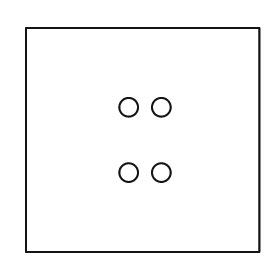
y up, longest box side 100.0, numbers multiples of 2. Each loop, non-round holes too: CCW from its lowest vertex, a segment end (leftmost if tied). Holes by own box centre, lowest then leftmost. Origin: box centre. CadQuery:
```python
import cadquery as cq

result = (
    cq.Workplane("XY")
    .moveTo(-50.0, -48.0)
    .lineTo(50.0, -48.0)
    .lineTo(50.0, 48.0)
    .lineTo(-50.0, 48.0)
    .close()
    .moveTo(-6.0, -14.0)
    .circle(4.0)
    .moveTo(8.0, -14.0)
    .circle(4.0)
    .moveTo(-6.0, 14.0)
    .circle(4.0)
    .moveTo(8.0, 14.0)
    .circle(4.0)
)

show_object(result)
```